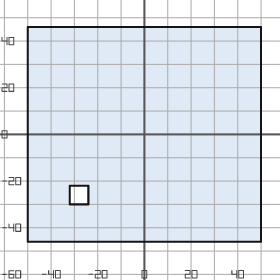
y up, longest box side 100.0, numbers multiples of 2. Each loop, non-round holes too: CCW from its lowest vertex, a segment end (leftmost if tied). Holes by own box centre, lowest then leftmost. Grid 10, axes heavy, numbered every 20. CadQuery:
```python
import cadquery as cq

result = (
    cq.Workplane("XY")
    .moveTo(-50.0, -46.0)
    .lineTo(50.0, -46.0)
    .lineTo(50.0, 46.0)
    .lineTo(-50.0, 46.0)
    .close()
    .moveTo(-32.0, -30.0)
    .lineTo(-24.0, -30.0)
    .lineTo(-24.0, -22.0)
    .lineTo(-32.0, -22.0)
    .close()
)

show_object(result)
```